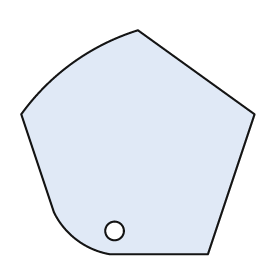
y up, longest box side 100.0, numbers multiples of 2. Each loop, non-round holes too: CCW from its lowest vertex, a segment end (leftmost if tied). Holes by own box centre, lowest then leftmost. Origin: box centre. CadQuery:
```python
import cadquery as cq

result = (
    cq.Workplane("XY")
    .moveTo(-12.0, -48.0)
    .lineTo(30.0, -48.0)
    .lineTo(50.0, 12.0)
    .lineTo(0.0, 48.0)
    .threePointArc((-28.0, 34.0), (-50.0, 12.0))
    .lineTo(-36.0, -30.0)
    .threePointArc((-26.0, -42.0), (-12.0, -48.0))
    .close()
    .moveTo(-10.0, -38.0)
    .circle(4.0)
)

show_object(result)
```